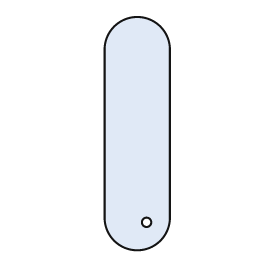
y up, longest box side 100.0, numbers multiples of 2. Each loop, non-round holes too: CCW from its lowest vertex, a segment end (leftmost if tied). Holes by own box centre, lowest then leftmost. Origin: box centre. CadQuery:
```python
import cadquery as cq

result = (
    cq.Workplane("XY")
    .moveTo(-14.0, -36.0)
    .threePointArc((0.0, -50.0), (14.0, -36.0))
    .lineTo(14.0, 36.0)
    .threePointArc((0.0, 50.0), (-14.0, 36.0))
    .close()
    .moveTo(4.0, -38.0)
    .circle(2.0)
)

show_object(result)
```